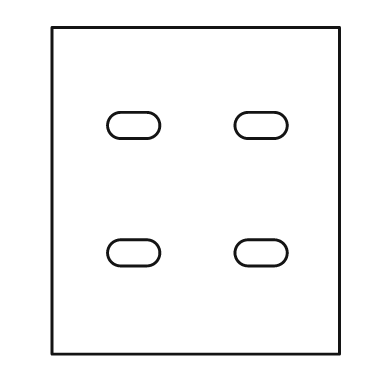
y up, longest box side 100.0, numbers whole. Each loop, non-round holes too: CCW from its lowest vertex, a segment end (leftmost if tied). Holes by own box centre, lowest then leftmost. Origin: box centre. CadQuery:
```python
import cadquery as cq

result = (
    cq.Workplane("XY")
    .moveTo(-44.0, -50.0)
    .lineTo(44.0, -50.0)
    .lineTo(44.0, 50.0)
    .lineTo(-44.0, 50.0)
    .close()
    .moveTo(-23.0, -23.0)
    .lineTo(-15.0, -23.0)
    .threePointArc((-11.0, -19.0), (-15.0, -15.0))
    .lineTo(-23.0, -15.0)
    .threePointArc((-27.0, -19.0), (-23.0, -23.0))
    .close()
    .moveTo(16.0, -23.0)
    .lineTo(24.0, -23.0)
    .threePointArc((28.0, -19.0), (24.0, -15.0))
    .lineTo(16.0, -15.0)
    .threePointArc((12.0, -19.0), (16.0, -23.0))
    .close()
    .moveTo(-23.0, 16.0)
    .lineTo(-15.0, 16.0)
    .threePointArc((-11.0, 20.0), (-15.0, 24.0))
    .lineTo(-23.0, 24.0)
    .threePointArc((-27.0, 20.0), (-23.0, 16.0))
    .close()
    .moveTo(16.0, 16.0)
    .lineTo(24.0, 16.0)
    .threePointArc((28.0, 20.0), (24.0, 24.0))
    .lineTo(16.0, 24.0)
    .threePointArc((12.0, 20.0), (16.0, 16.0))
    .close()
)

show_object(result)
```